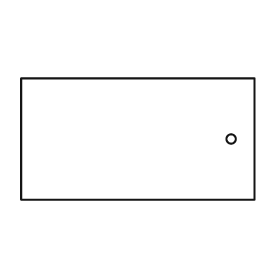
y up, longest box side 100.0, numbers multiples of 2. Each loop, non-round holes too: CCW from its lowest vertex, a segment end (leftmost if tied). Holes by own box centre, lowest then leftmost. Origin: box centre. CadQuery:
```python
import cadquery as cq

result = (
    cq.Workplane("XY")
    .moveTo(-50.0, -26.0)
    .lineTo(50.0, -26.0)
    .lineTo(50.0, 26.0)
    .lineTo(-50.0, 26.0)
    .close()
    .moveTo(40.0, 0.0)
    .circle(2.0)
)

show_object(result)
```